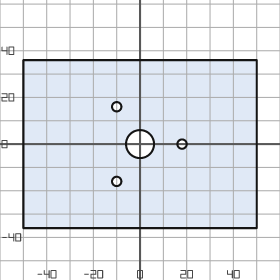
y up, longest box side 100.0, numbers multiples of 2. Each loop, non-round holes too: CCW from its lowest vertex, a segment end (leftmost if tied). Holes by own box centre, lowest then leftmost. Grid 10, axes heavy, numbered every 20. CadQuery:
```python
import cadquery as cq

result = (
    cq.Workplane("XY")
    .moveTo(-50.0, -36.0)
    .lineTo(50.0, -36.0)
    .lineTo(50.0, 36.0)
    .lineTo(-50.0, 36.0)
    .close()
    .moveTo(-10.0, -16.0)
    .circle(2.0)
    .moveTo(0.0, 0.0)
    .circle(6.0)
    .moveTo(18.0, 0.0)
    .circle(2.0)
    .moveTo(-10.0, 16.0)
    .circle(2.0)
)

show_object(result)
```